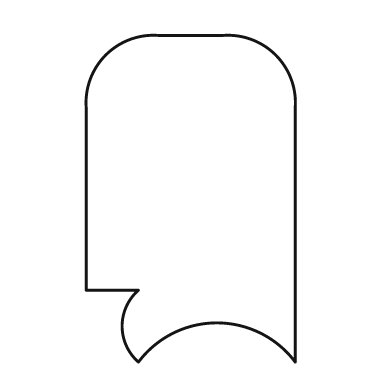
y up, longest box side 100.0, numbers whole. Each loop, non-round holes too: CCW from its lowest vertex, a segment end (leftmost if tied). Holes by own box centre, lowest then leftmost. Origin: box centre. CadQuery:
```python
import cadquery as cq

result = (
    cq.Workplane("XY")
    .moveTo(-16.0, -50.0)
    .threePointArc((8.0, -38.0), (32.0, -50.0))
    .lineTo(32.0, 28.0)
    .threePointArc((26.0, 44.0), (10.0, 50.0))
    .lineTo(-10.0, 50.0)
    .threePointArc((-26.0, 44.0), (-32.0, 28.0))
    .lineTo(-32.0, -28.0)
    .lineTo(-16.0, -28.0)
    .threePointArc((-21.0, -39.0), (-16.0, -50.0))
    .close()
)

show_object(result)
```